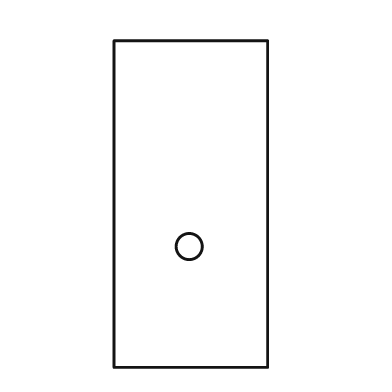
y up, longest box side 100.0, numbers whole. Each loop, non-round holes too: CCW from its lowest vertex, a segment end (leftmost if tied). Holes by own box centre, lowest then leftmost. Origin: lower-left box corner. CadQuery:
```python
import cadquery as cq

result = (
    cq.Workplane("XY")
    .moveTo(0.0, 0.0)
    .lineTo(47.0, 0.0)
    .lineTo(47.0, 100.0)
    .lineTo(0.0, 100.0)
    .close()
    .moveTo(23.0, 37.0)
    .circle(4.0)
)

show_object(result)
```